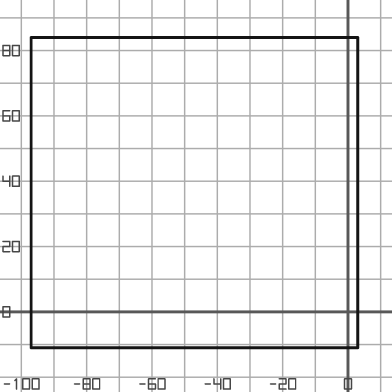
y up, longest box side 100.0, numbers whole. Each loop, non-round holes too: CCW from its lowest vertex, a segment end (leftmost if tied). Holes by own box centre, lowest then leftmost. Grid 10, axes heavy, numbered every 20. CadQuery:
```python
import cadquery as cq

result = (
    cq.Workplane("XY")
    .moveTo(-97.0, -11.0)
    .lineTo(3.0, -11.0)
    .lineTo(3.0, 84.0)
    .lineTo(-97.0, 84.0)
    .close()
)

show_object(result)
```